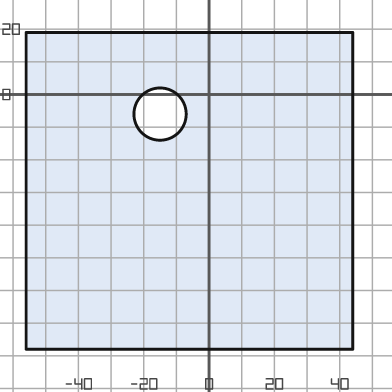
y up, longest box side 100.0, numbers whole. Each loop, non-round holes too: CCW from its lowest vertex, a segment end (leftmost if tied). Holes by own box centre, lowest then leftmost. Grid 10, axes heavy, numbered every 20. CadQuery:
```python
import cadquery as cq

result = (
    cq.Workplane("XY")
    .moveTo(-56.0, -78.0)
    .lineTo(44.0, -78.0)
    .lineTo(44.0, 19.0)
    .lineTo(-56.0, 19.0)
    .close()
    .moveTo(-15.0, -6.0)
    .circle(8.0)
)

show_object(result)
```